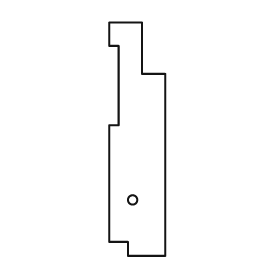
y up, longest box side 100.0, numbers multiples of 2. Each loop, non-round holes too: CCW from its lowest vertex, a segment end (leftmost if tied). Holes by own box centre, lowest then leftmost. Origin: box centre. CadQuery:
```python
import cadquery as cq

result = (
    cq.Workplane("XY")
    .moveTo(-4.0, -50.0)
    .lineTo(12.0, -50.0)
    .lineTo(12.0, 28.0)
    .lineTo(2.0, 28.0)
    .lineTo(2.0, 50.0)
    .lineTo(-12.0, 50.0)
    .lineTo(-12.0, 40.0)
    .lineTo(-8.0, 40.0)
    .lineTo(-8.0, 6.0)
    .lineTo(-12.0, 6.0)
    .lineTo(-12.0, -44.0)
    .lineTo(-4.0, -44.0)
    .close()
    .moveTo(-2.0, -26.0)
    .circle(2.0)
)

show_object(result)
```